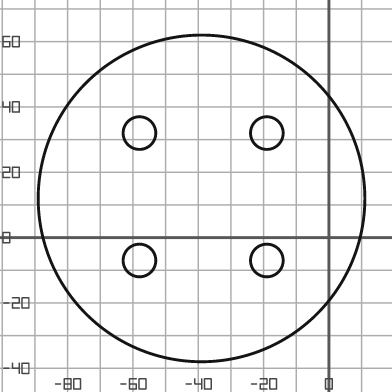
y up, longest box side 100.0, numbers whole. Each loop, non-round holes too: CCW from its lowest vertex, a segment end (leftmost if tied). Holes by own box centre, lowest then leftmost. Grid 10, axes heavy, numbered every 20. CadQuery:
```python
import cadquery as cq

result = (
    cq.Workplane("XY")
    .moveTo(-39.0, 12.0)
    .circle(50.0)
    .moveTo(-58.0, -7.0)
    .circle(5.0)
    .moveTo(-19.0, -7.0)
    .circle(5.0)
    .moveTo(-58.0, 32.0)
    .circle(5.0)
    .moveTo(-19.0, 32.0)
    .circle(5.0)
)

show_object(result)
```